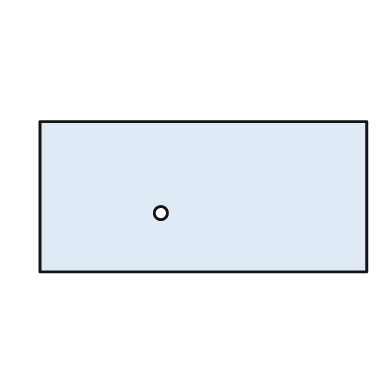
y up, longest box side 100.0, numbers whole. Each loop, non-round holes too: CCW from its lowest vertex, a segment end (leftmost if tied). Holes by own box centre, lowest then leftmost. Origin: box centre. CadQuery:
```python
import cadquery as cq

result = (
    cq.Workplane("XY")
    .moveTo(-50.0, -23.0)
    .lineTo(50.0, -23.0)
    .lineTo(50.0, 23.0)
    .lineTo(-50.0, 23.0)
    .close()
    .moveTo(-13.0, -5.0)
    .circle(2.0)
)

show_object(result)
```